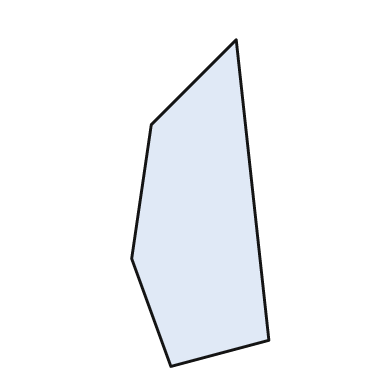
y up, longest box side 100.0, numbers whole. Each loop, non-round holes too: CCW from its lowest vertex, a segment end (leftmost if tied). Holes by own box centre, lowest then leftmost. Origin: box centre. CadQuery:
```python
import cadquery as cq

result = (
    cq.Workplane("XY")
    .moveTo(-9.0, -50.0)
    .lineTo(21.0, -42.0)
    .lineTo(11.0, 50.0)
    .lineTo(-15.0, 24.0)
    .lineTo(-21.0, -17.0)
    .close()
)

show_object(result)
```